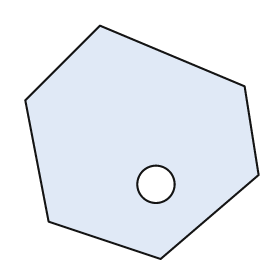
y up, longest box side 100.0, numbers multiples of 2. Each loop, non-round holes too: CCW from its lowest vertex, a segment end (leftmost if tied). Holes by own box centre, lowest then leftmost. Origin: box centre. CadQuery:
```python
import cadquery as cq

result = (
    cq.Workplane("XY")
    .moveTo(8.0, -50.0)
    .lineTo(50.0, -14.0)
    .lineTo(44.0, 24.0)
    .lineTo(-18.0, 50.0)
    .lineTo(-50.0, 18.0)
    .lineTo(-40.0, -34.0)
    .close()
    .moveTo(6.0, -18.0)
    .circle(8.0)
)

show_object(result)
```